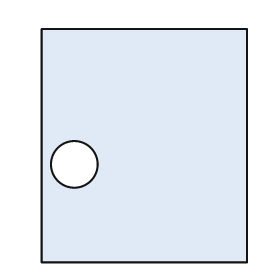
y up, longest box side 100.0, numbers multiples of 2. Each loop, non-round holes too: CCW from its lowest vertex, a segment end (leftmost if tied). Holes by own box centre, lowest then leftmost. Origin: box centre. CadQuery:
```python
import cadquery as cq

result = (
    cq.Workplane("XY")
    .moveTo(-44.0, -50.0)
    .lineTo(44.0, -50.0)
    .lineTo(44.0, 50.0)
    .lineTo(-44.0, 50.0)
    .close()
    .moveTo(-30.0, -8.0)
    .circle(10.0)
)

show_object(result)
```